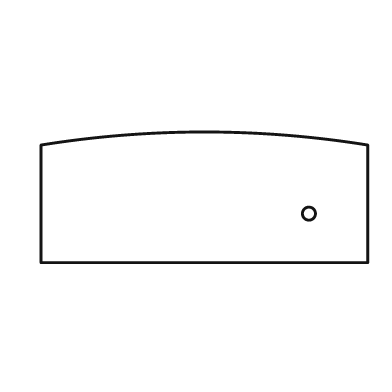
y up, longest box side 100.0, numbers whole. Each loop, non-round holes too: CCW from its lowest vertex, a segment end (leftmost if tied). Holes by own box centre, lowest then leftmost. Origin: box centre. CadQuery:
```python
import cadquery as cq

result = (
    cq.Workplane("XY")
    .moveTo(-50.0, -20.0)
    .lineTo(50.0, -20.0)
    .lineTo(50.0, 16.0)
    .threePointArc((0.0, 20.0), (-50.0, 16.0))
    .close()
    .moveTo(32.0, -5.0)
    .circle(2.0)
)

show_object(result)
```